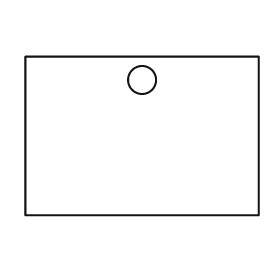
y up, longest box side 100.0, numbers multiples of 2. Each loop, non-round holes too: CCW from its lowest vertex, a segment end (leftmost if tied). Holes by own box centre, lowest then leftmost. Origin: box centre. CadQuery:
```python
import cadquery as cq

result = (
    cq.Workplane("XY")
    .moveTo(-50.0, -34.0)
    .lineTo(50.0, -34.0)
    .lineTo(50.0, 34.0)
    .lineTo(-50.0, 34.0)
    .close()
    .moveTo(0.0, 24.0)
    .circle(6.0)
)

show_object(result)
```